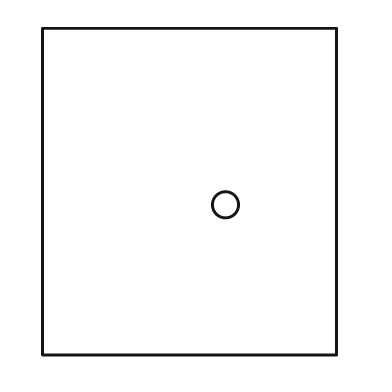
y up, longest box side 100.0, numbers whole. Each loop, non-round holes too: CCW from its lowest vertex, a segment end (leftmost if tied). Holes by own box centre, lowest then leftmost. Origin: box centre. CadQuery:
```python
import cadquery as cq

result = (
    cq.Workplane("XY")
    .moveTo(-45.0, -50.0)
    .lineTo(45.0, -50.0)
    .lineTo(45.0, 50.0)
    .lineTo(-45.0, 50.0)
    .close()
    .moveTo(11.0, -4.0)
    .circle(4.0)
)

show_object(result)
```